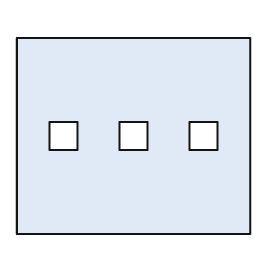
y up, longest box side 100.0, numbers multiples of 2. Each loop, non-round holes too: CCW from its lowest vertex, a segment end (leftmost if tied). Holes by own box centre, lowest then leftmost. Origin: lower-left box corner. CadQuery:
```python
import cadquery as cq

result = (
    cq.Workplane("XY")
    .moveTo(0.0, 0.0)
    .lineTo(100.0, 0.0)
    .lineTo(100.0, 84.0)
    .lineTo(0.0, 84.0)
    .close()
    .moveTo(14.0, 36.0)
    .lineTo(26.0, 36.0)
    .lineTo(26.0, 48.0)
    .lineTo(14.0, 48.0)
    .close()
    .moveTo(44.0, 36.0)
    .lineTo(56.0, 36.0)
    .lineTo(56.0, 48.0)
    .lineTo(44.0, 48.0)
    .close()
    .moveTo(74.0, 36.0)
    .lineTo(86.0, 36.0)
    .lineTo(86.0, 48.0)
    .lineTo(74.0, 48.0)
    .close()
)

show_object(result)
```